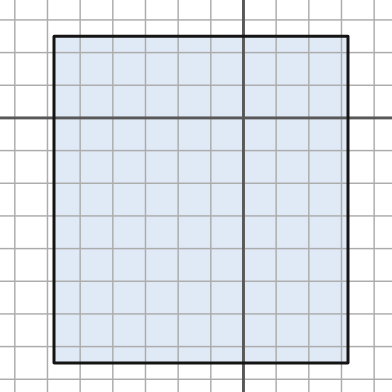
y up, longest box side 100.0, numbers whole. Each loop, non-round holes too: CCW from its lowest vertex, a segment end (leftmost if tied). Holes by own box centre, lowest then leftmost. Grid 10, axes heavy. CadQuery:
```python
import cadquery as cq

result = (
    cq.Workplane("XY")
    .moveTo(-58.0, -75.0)
    .lineTo(32.0, -75.0)
    .lineTo(32.0, 25.0)
    .lineTo(-58.0, 25.0)
    .close()
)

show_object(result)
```